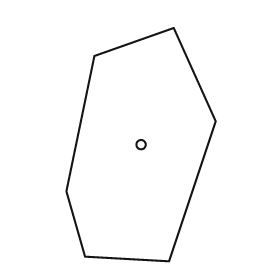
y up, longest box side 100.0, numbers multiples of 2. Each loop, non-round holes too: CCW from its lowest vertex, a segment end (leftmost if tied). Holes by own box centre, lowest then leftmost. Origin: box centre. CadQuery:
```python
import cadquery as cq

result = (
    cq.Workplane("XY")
    .moveTo(12.0, -50.0)
    .lineTo(32.0, 10.0)
    .lineTo(14.0, 50.0)
    .lineTo(-20.0, 38.0)
    .lineTo(-32.0, -20.0)
    .lineTo(-24.0, -48.0)
    .close()
    .moveTo(0.0, 0.0)
    .circle(2.0)
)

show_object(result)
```